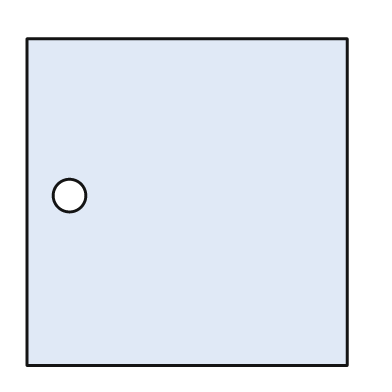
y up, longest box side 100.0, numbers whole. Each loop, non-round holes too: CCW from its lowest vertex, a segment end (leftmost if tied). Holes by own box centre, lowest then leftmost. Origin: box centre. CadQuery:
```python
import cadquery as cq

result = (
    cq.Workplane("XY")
    .moveTo(-49.0, -50.0)
    .lineTo(49.0, -50.0)
    .lineTo(49.0, 50.0)
    .lineTo(-49.0, 50.0)
    .close()
    .moveTo(-36.0, 2.0)
    .circle(5.0)
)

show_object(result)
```